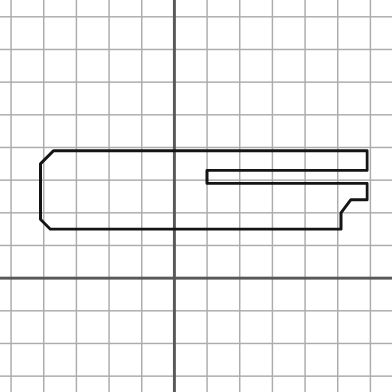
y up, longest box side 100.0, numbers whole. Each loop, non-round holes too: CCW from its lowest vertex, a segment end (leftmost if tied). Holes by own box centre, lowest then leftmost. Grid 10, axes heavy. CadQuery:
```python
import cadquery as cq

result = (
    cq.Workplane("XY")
    .moveTo(-38.0, 15.0)
    .lineTo(51.0, 15.0)
    .lineTo(51.0, 20.0)
    .lineTo(54.0, 24.0)
    .lineTo(59.0, 24.0)
    .lineTo(59.0, 29.0)
    .lineTo(10.0, 29.0)
    .lineTo(10.0, 33.0)
    .lineTo(59.0, 33.0)
    .lineTo(59.0, 39.0)
    .lineTo(-37.0, 39.0)
    .lineTo(-41.0, 35.0)
    .lineTo(-41.0, 18.0)
    .close()
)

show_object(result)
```